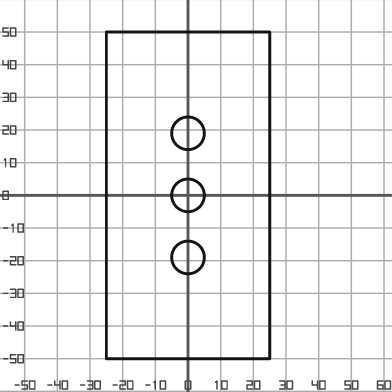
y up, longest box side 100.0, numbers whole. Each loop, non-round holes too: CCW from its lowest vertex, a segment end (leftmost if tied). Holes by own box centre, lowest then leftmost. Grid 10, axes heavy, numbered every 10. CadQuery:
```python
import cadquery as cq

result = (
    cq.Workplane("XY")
    .moveTo(-25.0, -50.0)
    .lineTo(25.0, -50.0)
    .lineTo(25.0, 50.0)
    .lineTo(-25.0, 50.0)
    .close()
    .moveTo(0.0, -19.0)
    .circle(5.0)
    .moveTo(0.0, 0.0)
    .circle(5.0)
    .moveTo(0.0, 19.0)
    .circle(5.0)
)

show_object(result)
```